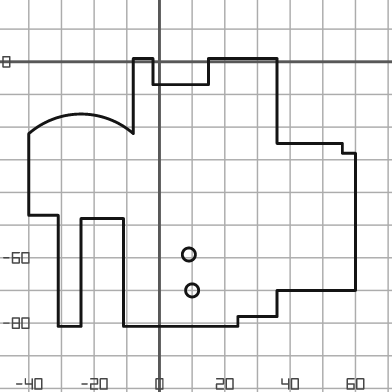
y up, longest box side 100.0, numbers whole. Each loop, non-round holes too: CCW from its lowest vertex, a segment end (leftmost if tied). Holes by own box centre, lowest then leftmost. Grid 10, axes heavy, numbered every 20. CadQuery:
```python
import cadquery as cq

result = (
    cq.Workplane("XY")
    .moveTo(-31.0, -81.0)
    .lineTo(-24.0, -81.0)
    .lineTo(-24.0, -48.0)
    .lineTo(-11.0, -48.0)
    .lineTo(-11.0, -81.0)
    .lineTo(24.0, -81.0)
    .lineTo(24.0, -78.0)
    .lineTo(36.0, -78.0)
    .lineTo(36.0, -70.0)
    .lineTo(60.0, -70.0)
    .lineTo(60.0, -28.0)
    .lineTo(56.0, -28.0)
    .lineTo(56.0, -25.0)
    .lineTo(36.0, -25.0)
    .lineTo(36.0, 1.0)
    .lineTo(15.0, 1.0)
    .lineTo(15.0, -7.0)
    .lineTo(-2.0, -7.0)
    .lineTo(-2.0, 1.0)
    .lineTo(-8.0, 1.0)
    .lineTo(-8.0, -22.0)
    .threePointArc((-24.0, -16.0), (-40.0, -22.0))
    .lineTo(-40.0, -47.0)
    .lineTo(-31.0, -47.0)
    .close()
    .moveTo(10.0, -70.0)
    .circle(2.0)
    .moveTo(9.0, -59.0)
    .circle(2.0)
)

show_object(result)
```